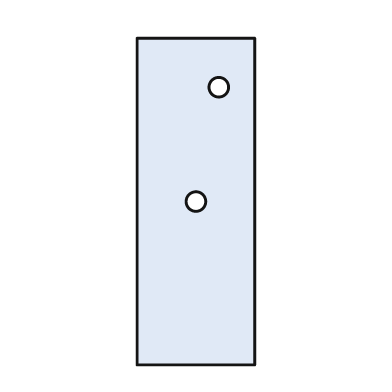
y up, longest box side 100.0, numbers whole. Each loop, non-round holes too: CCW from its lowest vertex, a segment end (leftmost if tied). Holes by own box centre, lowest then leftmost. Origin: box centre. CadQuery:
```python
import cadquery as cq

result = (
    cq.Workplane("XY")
    .moveTo(-18.0, -50.0)
    .lineTo(18.0, -50.0)
    .lineTo(18.0, 50.0)
    .lineTo(-18.0, 50.0)
    .close()
    .moveTo(0.0, 0.0)
    .circle(3.0)
    .moveTo(7.0, 35.0)
    .circle(3.0)
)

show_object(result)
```